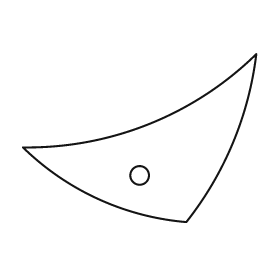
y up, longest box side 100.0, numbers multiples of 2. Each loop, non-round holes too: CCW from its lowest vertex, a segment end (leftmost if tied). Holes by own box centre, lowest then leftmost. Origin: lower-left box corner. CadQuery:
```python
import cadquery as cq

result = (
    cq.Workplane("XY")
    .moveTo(70.0, 0.0)
    .threePointArc((90.0, 34.0), (100.0, 72.0))
    .threePointArc((54.0, 42.0), (0.0, 32.0))
    .threePointArc((32.0, 10.0), (70.0, 0.0))
    .close()
    .moveTo(50.0, 20.0)
    .circle(4.0)
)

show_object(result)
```